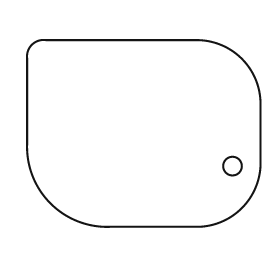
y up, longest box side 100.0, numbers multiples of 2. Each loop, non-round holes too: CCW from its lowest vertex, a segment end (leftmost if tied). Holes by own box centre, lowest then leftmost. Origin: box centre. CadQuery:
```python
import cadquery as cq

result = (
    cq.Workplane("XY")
    .moveTo(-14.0, -40.0)
    .lineTo(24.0, -40.0)
    .threePointArc((42.0, -32.0), (50.0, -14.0))
    .lineTo(50.0, 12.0)
    .threePointArc((42.0, 32.0), (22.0, 40.0))
    .lineTo(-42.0, 40.0)
    .threePointArc((-48.0, 38.0), (-50.0, 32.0))
    .lineTo(-50.0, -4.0)
    .threePointArc((-40.0, -30.0), (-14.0, -40.0))
    .close()
    .moveTo(38.0, -14.0)
    .circle(4.0)
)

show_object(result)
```